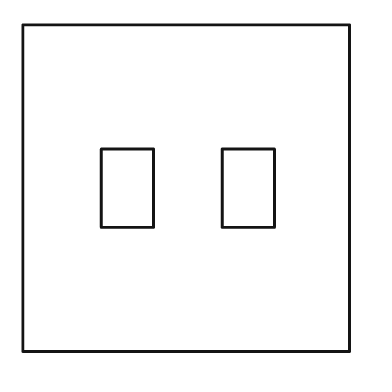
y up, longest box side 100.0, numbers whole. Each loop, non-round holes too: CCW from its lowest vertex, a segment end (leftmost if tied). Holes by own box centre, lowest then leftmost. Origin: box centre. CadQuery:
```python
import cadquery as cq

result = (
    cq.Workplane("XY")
    .moveTo(-50.0, -50.0)
    .lineTo(50.0, -50.0)
    .lineTo(50.0, 50.0)
    .lineTo(-50.0, 50.0)
    .close()
    .moveTo(-26.0, -12.0)
    .lineTo(-10.0, -12.0)
    .lineTo(-10.0, 12.0)
    .lineTo(-26.0, 12.0)
    .close()
    .moveTo(11.0, -12.0)
    .lineTo(27.0, -12.0)
    .lineTo(27.0, 12.0)
    .lineTo(11.0, 12.0)
    .close()
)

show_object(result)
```